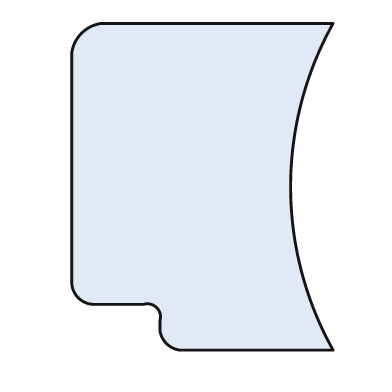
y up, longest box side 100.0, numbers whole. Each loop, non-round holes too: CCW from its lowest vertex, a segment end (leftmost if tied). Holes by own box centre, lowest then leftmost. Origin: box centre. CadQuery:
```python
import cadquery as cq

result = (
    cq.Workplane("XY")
    .moveTo(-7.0, -50.0)
    .lineTo(40.0, -50.0)
    .threePointArc((27.0, 0.0), (40.0, 50.0))
    .lineTo(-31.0, 50.0)
    .threePointArc((-37.0, 47.0), (-40.0, 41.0))
    .lineTo(-40.0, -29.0)
    .threePointArc((-38.0, -34.0), (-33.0, -36.0))
    .lineTo(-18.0, -36.0)
    .threePointArc((-14.0, -37.0), (-13.0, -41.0))
    .lineTo(-13.0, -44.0)
    .threePointArc((-11.0, -48.0), (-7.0, -50.0))
    .close()
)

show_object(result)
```